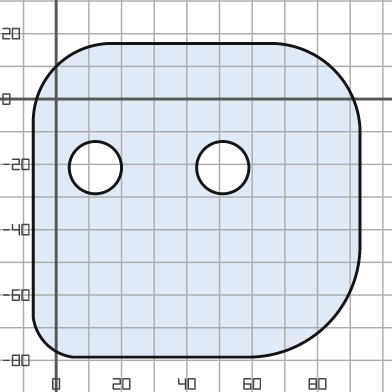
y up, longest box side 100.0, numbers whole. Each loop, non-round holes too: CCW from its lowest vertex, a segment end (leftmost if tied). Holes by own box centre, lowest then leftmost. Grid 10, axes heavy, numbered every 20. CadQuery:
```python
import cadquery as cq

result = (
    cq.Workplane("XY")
    .moveTo(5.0, -79.0)
    .lineTo(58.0, -79.0)
    .threePointArc((83.0, -69.0), (93.0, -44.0))
    .lineTo(93.0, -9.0)
    .threePointArc((85.0, 9.0), (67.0, 17.0))
    .lineTo(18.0, 17.0)
    .threePointArc((0.0, 10.0), (-7.0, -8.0))
    .lineTo(-7.0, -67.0)
    .threePointArc((-3.0, -75.0), (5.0, -79.0))
    .close()
    .moveTo(12.0, -21.0)
    .circle(8.0)
    .moveTo(51.0, -21.0)
    .circle(8.0)
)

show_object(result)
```